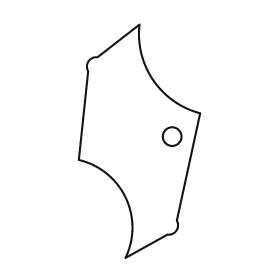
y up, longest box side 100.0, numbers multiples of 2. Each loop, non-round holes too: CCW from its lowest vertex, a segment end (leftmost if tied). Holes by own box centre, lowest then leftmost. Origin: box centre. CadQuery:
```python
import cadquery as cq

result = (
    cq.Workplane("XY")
    .moveTo(-6.0, -50.0)
    .lineTo(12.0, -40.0)
    .threePointArc((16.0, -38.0), (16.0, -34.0))
    .lineTo(26.0, 12.0)
    .threePointArc((6.0, 26.0), (0.0, 50.0))
    .lineTo(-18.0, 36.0)
    .threePointArc((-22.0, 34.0), (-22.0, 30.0))
    .lineTo(-26.0, -8.0)
    .threePointArc((-6.0, -24.0), (-6.0, -50.0))
    .close()
    .moveTo(14.0, 2.0)
    .circle(4.0)
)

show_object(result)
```